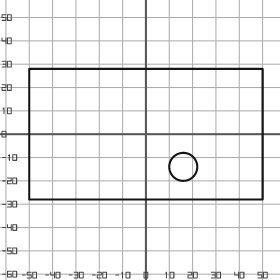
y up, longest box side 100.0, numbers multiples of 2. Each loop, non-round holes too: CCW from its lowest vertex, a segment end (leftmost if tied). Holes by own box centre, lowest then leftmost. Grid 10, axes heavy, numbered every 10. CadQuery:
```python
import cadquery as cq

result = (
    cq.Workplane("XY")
    .moveTo(-50.0, -28.0)
    .lineTo(50.0, -28.0)
    .lineTo(50.0, 28.0)
    .lineTo(-50.0, 28.0)
    .close()
    .moveTo(16.0, -14.0)
    .circle(6.0)
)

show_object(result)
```